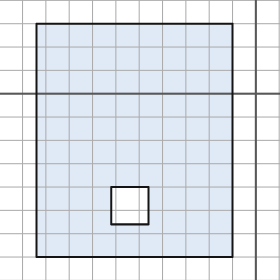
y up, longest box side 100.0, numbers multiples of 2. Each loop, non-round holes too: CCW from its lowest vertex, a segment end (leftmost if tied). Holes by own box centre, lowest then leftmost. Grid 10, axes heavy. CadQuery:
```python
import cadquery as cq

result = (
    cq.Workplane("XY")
    .moveTo(-94.0, -70.0)
    .lineTo(-10.0, -70.0)
    .lineTo(-10.0, 30.0)
    .lineTo(-94.0, 30.0)
    .close()
    .moveTo(-62.0, -56.0)
    .lineTo(-46.0, -56.0)
    .lineTo(-46.0, -40.0)
    .lineTo(-62.0, -40.0)
    .close()
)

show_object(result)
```